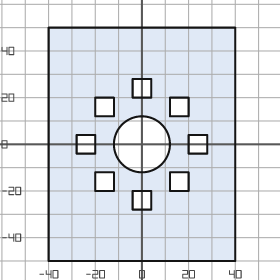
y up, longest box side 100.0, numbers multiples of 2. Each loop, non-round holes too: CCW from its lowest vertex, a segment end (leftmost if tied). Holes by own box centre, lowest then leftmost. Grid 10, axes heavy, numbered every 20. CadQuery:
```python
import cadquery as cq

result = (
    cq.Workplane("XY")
    .moveTo(-40.0, -50.0)
    .lineTo(40.0, -50.0)
    .lineTo(40.0, 50.0)
    .lineTo(-40.0, 50.0)
    .close()
    .moveTo(-4.0, -28.0)
    .lineTo(4.0, -28.0)
    .lineTo(4.0, -20.0)
    .lineTo(-4.0, -20.0)
    .close()
    .moveTo(-20.0, -20.0)
    .lineTo(-12.0, -20.0)
    .lineTo(-12.0, -12.0)
    .lineTo(-20.0, -12.0)
    .close()
    .moveTo(12.0, -20.0)
    .lineTo(20.0, -20.0)
    .lineTo(20.0, -12.0)
    .lineTo(12.0, -12.0)
    .close()
    .moveTo(-28.0, -4.0)
    .lineTo(-20.0, -4.0)
    .lineTo(-20.0, 4.0)
    .lineTo(-28.0, 4.0)
    .close()
    .moveTo(0.0, 0.0)
    .circle(12.0)
    .moveTo(20.0, -4.0)
    .lineTo(28.0, -4.0)
    .lineTo(28.0, 4.0)
    .lineTo(20.0, 4.0)
    .close()
    .moveTo(-20.0, 12.0)
    .lineTo(-12.0, 12.0)
    .lineTo(-12.0, 20.0)
    .lineTo(-20.0, 20.0)
    .close()
    .moveTo(12.0, 12.0)
    .lineTo(20.0, 12.0)
    .lineTo(20.0, 20.0)
    .lineTo(12.0, 20.0)
    .close()
    .moveTo(-4.0, 20.0)
    .lineTo(4.0, 20.0)
    .lineTo(4.0, 28.0)
    .lineTo(-4.0, 28.0)
    .close()
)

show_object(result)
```